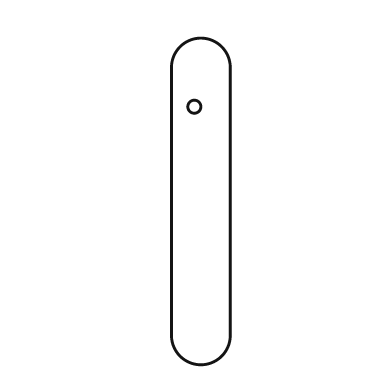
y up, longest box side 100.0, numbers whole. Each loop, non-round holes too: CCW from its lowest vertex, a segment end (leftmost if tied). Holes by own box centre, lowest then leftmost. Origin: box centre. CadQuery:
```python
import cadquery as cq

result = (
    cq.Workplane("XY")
    .moveTo(-9.0, -41.0)
    .threePointArc((0.0, -50.0), (9.0, -41.0))
    .lineTo(9.0, 41.0)
    .threePointArc((0.0, 50.0), (-9.0, 41.0))
    .close()
    .moveTo(-2.0, 29.0)
    .circle(2.0)
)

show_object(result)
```